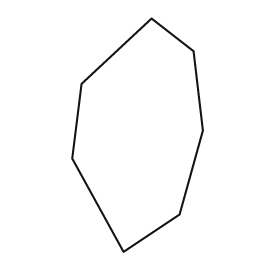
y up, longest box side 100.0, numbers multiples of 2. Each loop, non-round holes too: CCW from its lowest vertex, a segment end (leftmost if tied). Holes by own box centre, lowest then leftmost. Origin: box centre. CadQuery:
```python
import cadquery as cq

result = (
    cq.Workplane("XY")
    .moveTo(-6.0, -50.0)
    .lineTo(18.0, -34.0)
    .lineTo(28.0, 2.0)
    .lineTo(24.0, 36.0)
    .lineTo(6.0, 50.0)
    .lineTo(-24.0, 22.0)
    .lineTo(-28.0, -10.0)
    .close()
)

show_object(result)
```